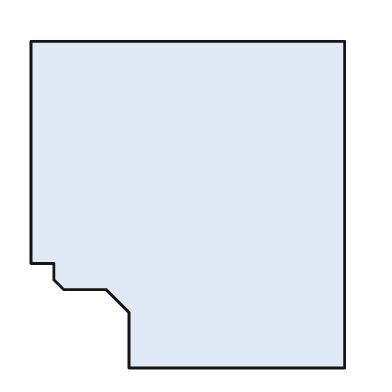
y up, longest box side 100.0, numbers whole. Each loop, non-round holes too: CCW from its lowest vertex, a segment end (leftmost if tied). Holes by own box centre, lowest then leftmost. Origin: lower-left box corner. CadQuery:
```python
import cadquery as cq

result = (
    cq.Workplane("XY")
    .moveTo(30.0, 0.0)
    .lineTo(96.0, 0.0)
    .lineTo(96.0, 100.0)
    .lineTo(0.0, 100.0)
    .lineTo(0.0, 32.0)
    .lineTo(7.0, 32.0)
    .lineTo(7.0, 27.0)
    .lineTo(10.0, 24.0)
    .lineTo(23.0, 24.0)
    .lineTo(30.0, 17.0)
    .close()
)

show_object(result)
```